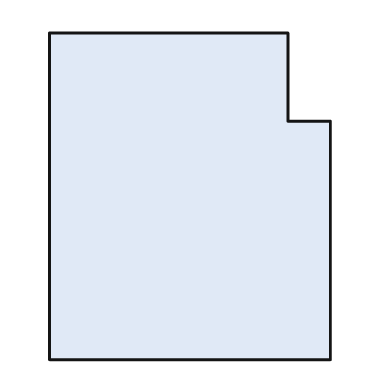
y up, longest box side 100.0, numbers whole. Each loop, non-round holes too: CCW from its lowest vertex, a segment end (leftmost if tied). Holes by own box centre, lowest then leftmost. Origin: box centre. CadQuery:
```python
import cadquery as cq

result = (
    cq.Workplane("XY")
    .moveTo(-43.0, -50.0)
    .lineTo(43.0, -50.0)
    .lineTo(43.0, 23.0)
    .lineTo(30.0, 23.0)
    .lineTo(30.0, 50.0)
    .lineTo(-43.0, 50.0)
    .close()
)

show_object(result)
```